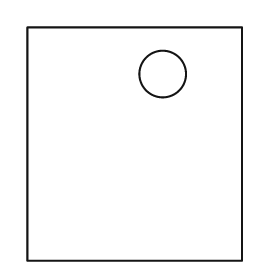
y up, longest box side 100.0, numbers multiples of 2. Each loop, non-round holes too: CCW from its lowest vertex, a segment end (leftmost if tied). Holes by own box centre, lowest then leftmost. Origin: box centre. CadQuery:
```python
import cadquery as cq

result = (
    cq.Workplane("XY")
    .moveTo(-46.0, -50.0)
    .lineTo(46.0, -50.0)
    .lineTo(46.0, 50.0)
    .lineTo(-46.0, 50.0)
    .close()
    .moveTo(12.0, 30.0)
    .circle(10.0)
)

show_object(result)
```